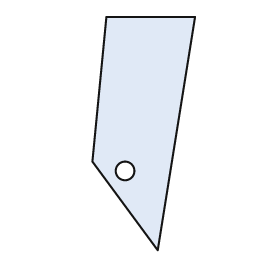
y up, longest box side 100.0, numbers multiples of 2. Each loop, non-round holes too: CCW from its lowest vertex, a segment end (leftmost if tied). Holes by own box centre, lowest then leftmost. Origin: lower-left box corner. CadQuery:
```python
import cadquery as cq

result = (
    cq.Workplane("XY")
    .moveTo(28.0, 0.0)
    .lineTo(44.0, 100.0)
    .lineTo(6.0, 100.0)
    .lineTo(0.0, 38.0)
    .close()
    .moveTo(14.0, 34.0)
    .circle(4.0)
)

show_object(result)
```